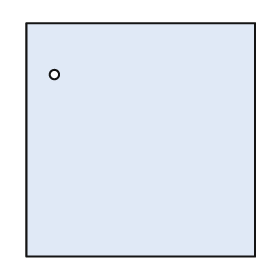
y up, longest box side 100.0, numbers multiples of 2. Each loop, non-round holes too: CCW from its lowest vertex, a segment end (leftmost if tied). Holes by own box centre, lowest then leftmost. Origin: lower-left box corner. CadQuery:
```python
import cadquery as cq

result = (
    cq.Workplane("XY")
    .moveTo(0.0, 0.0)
    .lineTo(98.0, 0.0)
    .lineTo(98.0, 100.0)
    .lineTo(0.0, 100.0)
    .close()
    .moveTo(12.0, 78.0)
    .circle(2.0)
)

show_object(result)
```